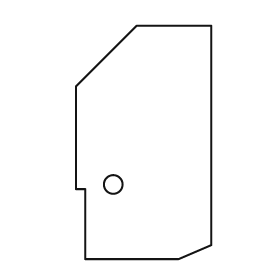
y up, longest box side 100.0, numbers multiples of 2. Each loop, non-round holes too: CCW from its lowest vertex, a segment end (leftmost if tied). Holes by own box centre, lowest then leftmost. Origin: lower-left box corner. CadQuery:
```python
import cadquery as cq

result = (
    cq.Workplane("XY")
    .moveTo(4.0, 0.0)
    .lineTo(44.0, 0.0)
    .lineTo(58.0, 6.0)
    .lineTo(58.0, 100.0)
    .lineTo(26.0, 100.0)
    .lineTo(0.0, 74.0)
    .lineTo(0.0, 30.0)
    .lineTo(4.0, 30.0)
    .close()
    .moveTo(16.0, 32.0)
    .circle(4.0)
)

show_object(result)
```